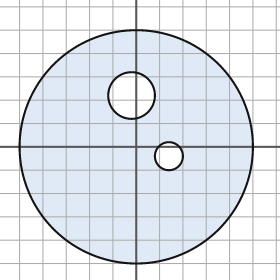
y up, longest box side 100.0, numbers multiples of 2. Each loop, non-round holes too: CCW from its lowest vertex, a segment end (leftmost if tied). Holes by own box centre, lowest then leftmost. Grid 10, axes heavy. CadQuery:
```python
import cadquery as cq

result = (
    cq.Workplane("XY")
    .moveTo(0.0, 0.0)
    .circle(50.0)
    .moveTo(14.0, -4.0)
    .circle(6.0)
    .moveTo(-2.0, 22.0)
    .circle(10.0)
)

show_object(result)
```